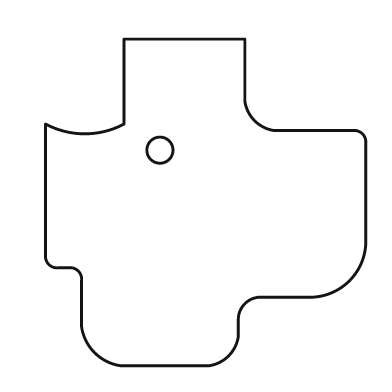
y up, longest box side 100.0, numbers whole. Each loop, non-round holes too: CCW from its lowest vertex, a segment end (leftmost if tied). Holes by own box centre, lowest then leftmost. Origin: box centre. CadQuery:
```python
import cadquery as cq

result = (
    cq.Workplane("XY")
    .moveTo(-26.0, -50.0)
    .lineTo(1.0, -50.0)
    .threePointArc((7.0, -47.0), (10.0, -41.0))
    .lineTo(10.0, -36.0)
    .threePointArc((12.0, -31.0), (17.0, -29.0))
    .lineTo(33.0, -29.0)
    .threePointArc((44.0, -24.0), (49.0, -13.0))
    .lineTo(49.0, 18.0)
    .threePointArc((48.0, 21.0), (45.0, 22.0))
    .lineTo(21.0, 22.0)
    .threePointArc((15.0, 25.0), (12.0, 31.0))
    .lineTo(12.0, 50.0)
    .lineTo(-25.0, 50.0)
    .lineTo(-25.0, 24.0)
    .threePointArc((-37.0, 21.0), (-49.0, 24.0))
    .lineTo(-49.0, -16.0)
    .threePointArc((-48.0, -19.0), (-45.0, -20.0))
    .lineTo(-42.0, -20.0)
    .threePointArc((-39.0, -21.0), (-38.0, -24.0))
    .lineTo(-38.0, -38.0)
    .threePointArc((-34.0, -46.0), (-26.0, -50.0))
    .close()
    .moveTo(-14.0, 16.0)
    .circle(4.0)
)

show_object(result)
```